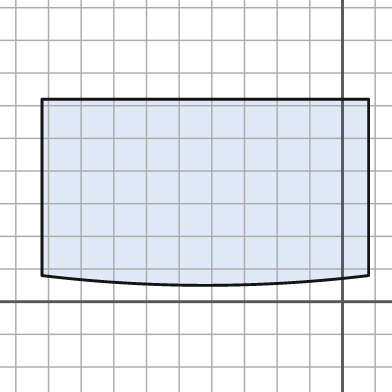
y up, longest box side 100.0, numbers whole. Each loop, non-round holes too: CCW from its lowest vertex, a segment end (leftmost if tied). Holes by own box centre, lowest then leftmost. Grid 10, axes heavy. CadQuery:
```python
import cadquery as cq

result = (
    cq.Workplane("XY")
    .moveTo(-92.0, 8.0)
    .threePointArc((-42.0, 5.0), (8.0, 8.0))
    .lineTo(8.0, 62.0)
    .lineTo(-92.0, 62.0)
    .close()
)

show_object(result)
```